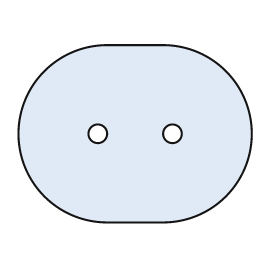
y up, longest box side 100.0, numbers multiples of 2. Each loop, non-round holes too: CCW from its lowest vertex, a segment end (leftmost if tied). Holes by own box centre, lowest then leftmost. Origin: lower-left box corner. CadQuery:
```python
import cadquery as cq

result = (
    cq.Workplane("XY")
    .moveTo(38.0, 0.0)
    .lineTo(62.0, 0.0)
    .threePointArc((100.0, 38.0), (62.0, 76.0))
    .lineTo(38.0, 76.0)
    .threePointArc((0.0, 38.0), (38.0, 0.0))
    .close()
    .moveTo(34.0, 38.0)
    .circle(4.0)
    .moveTo(66.0, 38.0)
    .circle(4.0)
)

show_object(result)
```